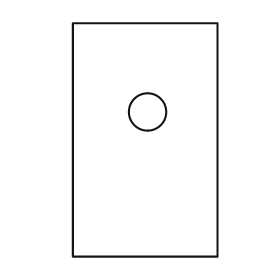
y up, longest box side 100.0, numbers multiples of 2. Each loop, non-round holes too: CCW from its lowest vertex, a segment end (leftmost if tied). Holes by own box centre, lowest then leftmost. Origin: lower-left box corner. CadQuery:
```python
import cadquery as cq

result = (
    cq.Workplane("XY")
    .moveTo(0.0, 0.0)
    .lineTo(62.0, 0.0)
    .lineTo(62.0, 100.0)
    .lineTo(0.0, 100.0)
    .close()
    .moveTo(32.0, 62.0)
    .circle(8.0)
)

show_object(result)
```